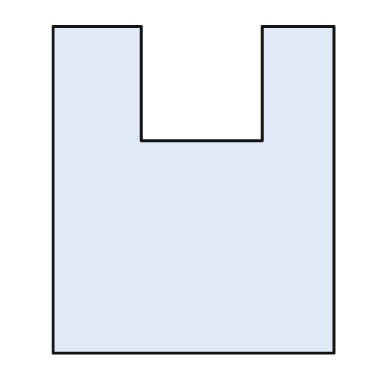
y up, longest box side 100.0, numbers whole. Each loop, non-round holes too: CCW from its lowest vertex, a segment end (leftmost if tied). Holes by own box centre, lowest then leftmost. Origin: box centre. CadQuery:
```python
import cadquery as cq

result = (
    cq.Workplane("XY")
    .moveTo(-43.0, -50.0)
    .lineTo(43.0, -50.0)
    .lineTo(43.0, 50.0)
    .lineTo(21.0, 50.0)
    .lineTo(21.0, 15.0)
    .lineTo(-16.0, 15.0)
    .lineTo(-16.0, 50.0)
    .lineTo(-43.0, 50.0)
    .close()
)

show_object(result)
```